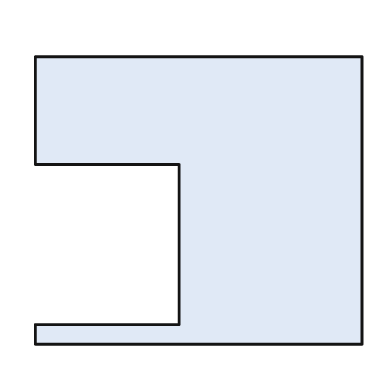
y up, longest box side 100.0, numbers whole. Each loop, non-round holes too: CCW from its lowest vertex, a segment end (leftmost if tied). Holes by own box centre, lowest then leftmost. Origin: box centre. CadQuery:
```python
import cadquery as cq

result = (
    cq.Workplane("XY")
    .moveTo(-50.0, -44.0)
    .lineTo(50.0, -44.0)
    .lineTo(50.0, 44.0)
    .lineTo(-50.0, 44.0)
    .lineTo(-50.0, 11.0)
    .lineTo(-6.0, 11.0)
    .lineTo(-6.0, -38.0)
    .lineTo(-50.0, -38.0)
    .close()
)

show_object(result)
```